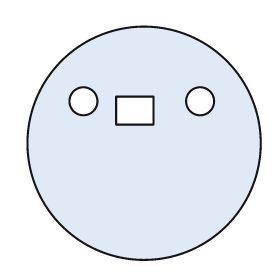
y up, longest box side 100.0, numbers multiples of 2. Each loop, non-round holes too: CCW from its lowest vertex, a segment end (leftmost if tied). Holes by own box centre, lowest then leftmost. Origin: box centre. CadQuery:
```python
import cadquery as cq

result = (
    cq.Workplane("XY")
    .moveTo(0.0, 0.0)
    .circle(50.0)
    .moveTo(-12.0, 8.0)
    .lineTo(4.0, 8.0)
    .lineTo(4.0, 20.0)
    .lineTo(-12.0, 20.0)
    .close()
    .moveTo(-26.0, 18.0)
    .circle(6.0)
    .moveTo(24.0, 18.0)
    .circle(6.0)
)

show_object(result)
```